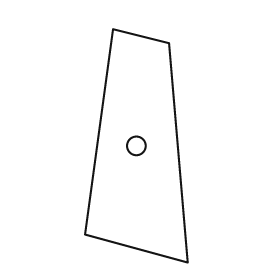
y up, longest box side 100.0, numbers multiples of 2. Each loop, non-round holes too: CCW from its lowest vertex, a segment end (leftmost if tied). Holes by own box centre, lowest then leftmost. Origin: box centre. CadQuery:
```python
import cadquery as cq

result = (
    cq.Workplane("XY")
    .moveTo(22.0, -50.0)
    .lineTo(14.0, 44.0)
    .lineTo(-10.0, 50.0)
    .lineTo(-22.0, -38.0)
    .close()
    .moveTo(0.0, 0.0)
    .circle(4.0)
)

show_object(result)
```